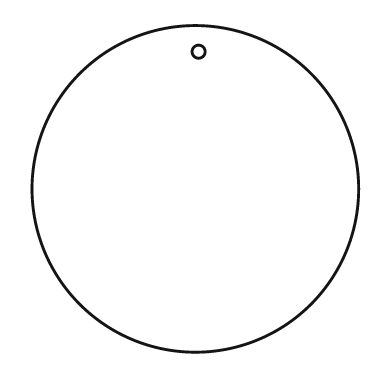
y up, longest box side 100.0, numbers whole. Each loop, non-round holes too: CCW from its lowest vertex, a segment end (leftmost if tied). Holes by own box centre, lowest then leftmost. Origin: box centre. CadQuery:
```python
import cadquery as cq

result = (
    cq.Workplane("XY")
    .moveTo(0.0, 0.0)
    .circle(50.0)
    .moveTo(1.0, 42.0)
    .circle(2.0)
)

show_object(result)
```